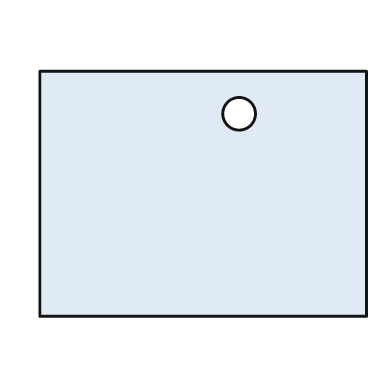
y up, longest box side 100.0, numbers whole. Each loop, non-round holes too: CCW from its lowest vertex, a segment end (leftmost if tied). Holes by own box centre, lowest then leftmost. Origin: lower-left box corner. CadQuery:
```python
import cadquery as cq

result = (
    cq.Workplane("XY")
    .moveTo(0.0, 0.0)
    .lineTo(100.0, 0.0)
    .lineTo(100.0, 75.0)
    .lineTo(0.0, 75.0)
    .close()
    .moveTo(61.0, 62.0)
    .circle(5.0)
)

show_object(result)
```